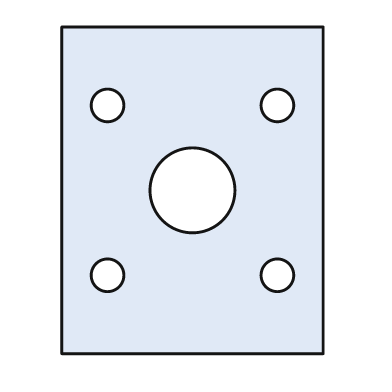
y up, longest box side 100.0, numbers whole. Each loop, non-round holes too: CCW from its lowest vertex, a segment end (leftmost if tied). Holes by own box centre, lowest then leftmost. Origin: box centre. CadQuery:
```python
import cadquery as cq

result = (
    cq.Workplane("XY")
    .moveTo(-40.0, -50.0)
    .lineTo(40.0, -50.0)
    .lineTo(40.0, 50.0)
    .lineTo(-40.0, 50.0)
    .close()
    .moveTo(-26.0, -26.0)
    .circle(5.0)
    .moveTo(26.0, -26.0)
    .circle(5.0)
    .moveTo(0.0, 0.0)
    .circle(13.0)
    .moveTo(-26.0, 26.0)
    .circle(5.0)
    .moveTo(26.0, 26.0)
    .circle(5.0)
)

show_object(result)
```